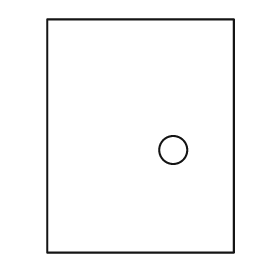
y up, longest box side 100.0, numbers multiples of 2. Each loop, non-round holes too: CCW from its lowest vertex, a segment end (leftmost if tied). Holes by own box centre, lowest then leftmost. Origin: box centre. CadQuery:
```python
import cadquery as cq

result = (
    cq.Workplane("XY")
    .moveTo(-40.0, -50.0)
    .lineTo(40.0, -50.0)
    .lineTo(40.0, 50.0)
    .lineTo(-40.0, 50.0)
    .close()
    .moveTo(14.0, -6.0)
    .circle(6.0)
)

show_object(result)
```